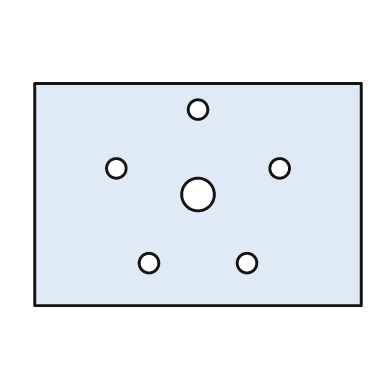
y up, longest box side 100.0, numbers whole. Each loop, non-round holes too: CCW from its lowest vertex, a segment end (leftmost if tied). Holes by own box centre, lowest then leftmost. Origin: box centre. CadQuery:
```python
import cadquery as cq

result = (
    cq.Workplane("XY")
    .moveTo(-50.0, -34.0)
    .lineTo(50.0, -34.0)
    .lineTo(50.0, 34.0)
    .lineTo(-50.0, 34.0)
    .close()
    .moveTo(-15.0, -21.0)
    .circle(3.0)
    .moveTo(15.0, -21.0)
    .circle(3.0)
    .moveTo(0.0, 0.0)
    .circle(5.0)
    .moveTo(-25.0, 8.0)
    .circle(3.0)
    .moveTo(25.0, 8.0)
    .circle(3.0)
    .moveTo(0.0, 26.0)
    .circle(3.0)
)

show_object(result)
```